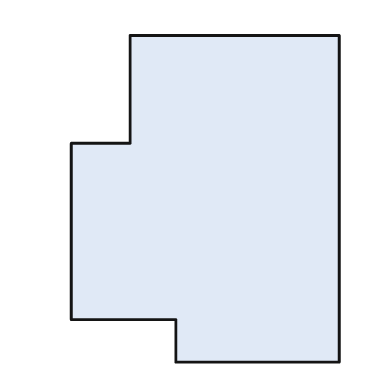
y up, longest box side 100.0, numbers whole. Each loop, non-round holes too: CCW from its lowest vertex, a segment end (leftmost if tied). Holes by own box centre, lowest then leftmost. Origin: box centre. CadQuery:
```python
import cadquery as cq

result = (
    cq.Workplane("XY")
    .moveTo(-9.0, -50.0)
    .lineTo(41.0, -50.0)
    .lineTo(41.0, 50.0)
    .lineTo(-23.0, 50.0)
    .lineTo(-23.0, 17.0)
    .lineTo(-41.0, 17.0)
    .lineTo(-41.0, -37.0)
    .lineTo(-9.0, -37.0)
    .close()
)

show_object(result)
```